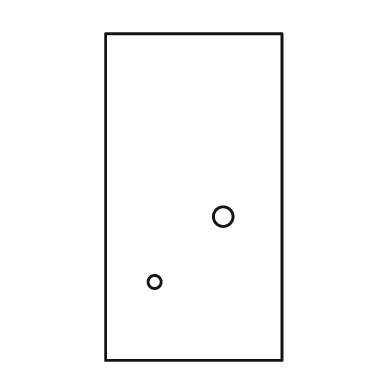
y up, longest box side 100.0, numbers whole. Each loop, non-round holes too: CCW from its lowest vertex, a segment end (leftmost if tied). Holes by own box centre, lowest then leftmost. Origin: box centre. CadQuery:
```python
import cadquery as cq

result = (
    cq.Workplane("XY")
    .moveTo(-27.0, -50.0)
    .lineTo(27.0, -50.0)
    .lineTo(27.0, 50.0)
    .lineTo(-27.0, 50.0)
    .close()
    .moveTo(-12.0, -26.0)
    .circle(2.0)
    .moveTo(9.0, -6.0)
    .circle(3.0)
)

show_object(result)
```